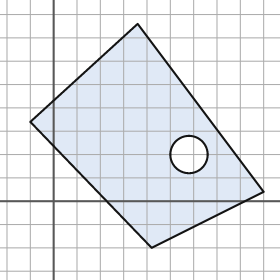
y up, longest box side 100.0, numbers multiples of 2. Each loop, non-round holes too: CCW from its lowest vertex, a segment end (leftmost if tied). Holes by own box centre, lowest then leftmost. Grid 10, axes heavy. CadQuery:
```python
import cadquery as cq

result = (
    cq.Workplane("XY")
    .moveTo(42.0, -20.0)
    .lineTo(90.0, 4.0)
    .lineTo(36.0, 76.0)
    .lineTo(-10.0, 34.0)
    .close()
    .moveTo(58.0, 20.0)
    .circle(8.0)
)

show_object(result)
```